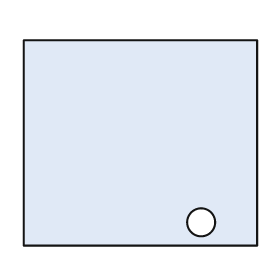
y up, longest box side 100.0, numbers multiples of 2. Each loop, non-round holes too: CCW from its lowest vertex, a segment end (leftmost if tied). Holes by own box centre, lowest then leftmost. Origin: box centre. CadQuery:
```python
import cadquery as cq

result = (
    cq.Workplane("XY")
    .moveTo(-50.0, -44.0)
    .lineTo(50.0, -44.0)
    .lineTo(50.0, 44.0)
    .lineTo(-50.0, 44.0)
    .close()
    .moveTo(26.0, -34.0)
    .circle(6.0)
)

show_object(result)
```